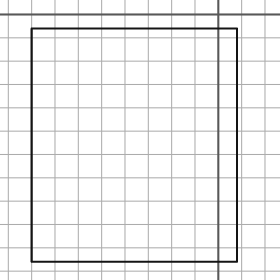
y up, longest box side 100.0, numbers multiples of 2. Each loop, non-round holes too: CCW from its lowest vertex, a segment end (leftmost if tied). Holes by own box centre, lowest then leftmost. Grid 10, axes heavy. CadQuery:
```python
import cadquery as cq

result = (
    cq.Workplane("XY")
    .moveTo(-80.0, -106.0)
    .lineTo(8.0, -106.0)
    .lineTo(8.0, -6.0)
    .lineTo(-80.0, -6.0)
    .close()
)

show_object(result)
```